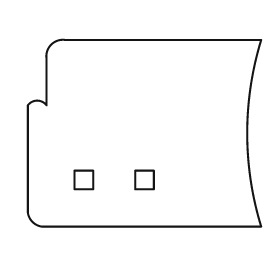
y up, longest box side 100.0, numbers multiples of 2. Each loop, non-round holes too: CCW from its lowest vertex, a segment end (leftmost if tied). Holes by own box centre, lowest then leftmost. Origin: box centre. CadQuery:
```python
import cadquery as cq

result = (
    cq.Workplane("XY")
    .moveTo(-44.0, -40.0)
    .lineTo(50.0, -40.0)
    .threePointArc((44.0, 0.0), (50.0, 40.0))
    .lineTo(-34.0, 40.0)
    .threePointArc((-40.0, 38.0), (-42.0, 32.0))
    .lineTo(-42.0, 12.0)
    .threePointArc((-46.0, 14.0), (-50.0, 12.0))
    .lineTo(-50.0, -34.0)
    .threePointArc((-48.0, -38.0), (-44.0, -40.0))
    .close()
    .moveTo(-30.0, -24.0)
    .lineTo(-22.0, -24.0)
    .lineTo(-22.0, -16.0)
    .lineTo(-30.0, -16.0)
    .close()
    .moveTo(-4.0, -24.0)
    .lineTo(4.0, -24.0)
    .lineTo(4.0, -16.0)
    .lineTo(-4.0, -16.0)
    .close()
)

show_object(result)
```